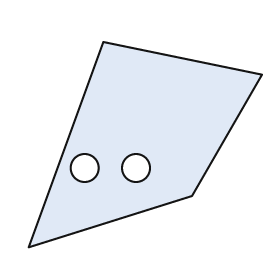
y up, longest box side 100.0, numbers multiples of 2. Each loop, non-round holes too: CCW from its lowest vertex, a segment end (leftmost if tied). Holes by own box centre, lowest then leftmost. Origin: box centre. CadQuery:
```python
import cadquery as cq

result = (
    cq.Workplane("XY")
    .moveTo(-50.0, -44.0)
    .lineTo(20.0, -22.0)
    .lineTo(50.0, 30.0)
    .lineTo(-18.0, 44.0)
    .close()
    .moveTo(-26.0, -10.0)
    .circle(6.0)
    .moveTo(-4.0, -10.0)
    .circle(6.0)
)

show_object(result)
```